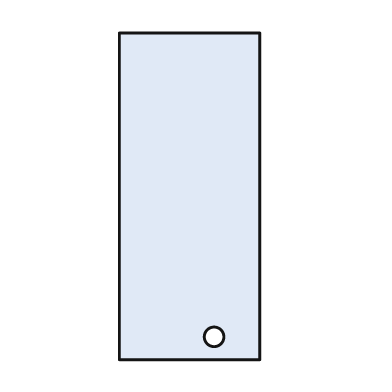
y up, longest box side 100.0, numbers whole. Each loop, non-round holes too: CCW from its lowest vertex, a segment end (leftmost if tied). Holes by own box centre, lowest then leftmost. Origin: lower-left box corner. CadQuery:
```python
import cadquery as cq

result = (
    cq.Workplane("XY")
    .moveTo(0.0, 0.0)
    .lineTo(43.0, 0.0)
    .lineTo(43.0, 100.0)
    .lineTo(0.0, 100.0)
    .close()
    .moveTo(29.0, 7.0)
    .circle(3.0)
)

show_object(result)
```